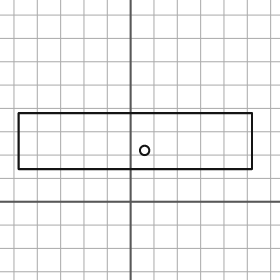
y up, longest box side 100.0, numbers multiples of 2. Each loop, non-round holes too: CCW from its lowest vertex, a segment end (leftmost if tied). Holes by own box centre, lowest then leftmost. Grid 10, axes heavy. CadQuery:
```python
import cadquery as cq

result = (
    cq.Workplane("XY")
    .moveTo(-48.0, 14.0)
    .lineTo(52.0, 14.0)
    .lineTo(52.0, 38.0)
    .lineTo(-48.0, 38.0)
    .close()
    .moveTo(6.0, 22.0)
    .circle(2.0)
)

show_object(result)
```